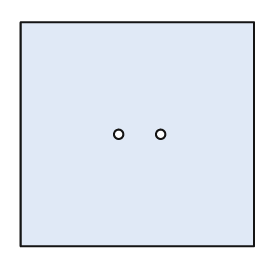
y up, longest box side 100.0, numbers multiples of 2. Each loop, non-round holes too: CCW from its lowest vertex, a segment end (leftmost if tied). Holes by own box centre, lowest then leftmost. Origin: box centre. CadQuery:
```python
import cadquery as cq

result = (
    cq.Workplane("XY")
    .moveTo(-50.0, -48.0)
    .lineTo(50.0, -48.0)
    .lineTo(50.0, 48.0)
    .lineTo(-50.0, 48.0)
    .close()
    .moveTo(-8.0, 0.0)
    .circle(2.0)
    .moveTo(10.0, 0.0)
    .circle(2.0)
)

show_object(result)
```